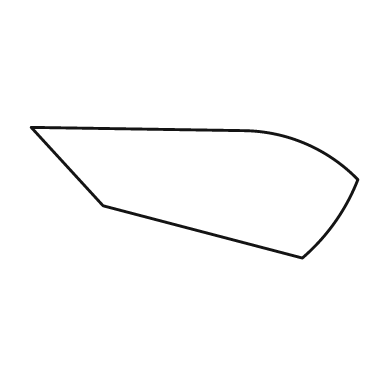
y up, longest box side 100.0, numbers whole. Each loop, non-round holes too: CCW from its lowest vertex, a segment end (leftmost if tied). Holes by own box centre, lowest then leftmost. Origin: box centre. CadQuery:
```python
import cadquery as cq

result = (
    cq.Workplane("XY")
    .moveTo(33.0, -20.0)
    .threePointArc((43.0, -9.0), (50.0, 4.0))
    .threePointArc((34.0, 15.0), (15.0, 19.0))
    .lineTo(-50.0, 20.0)
    .lineTo(-28.0, -4.0)
    .close()
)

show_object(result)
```